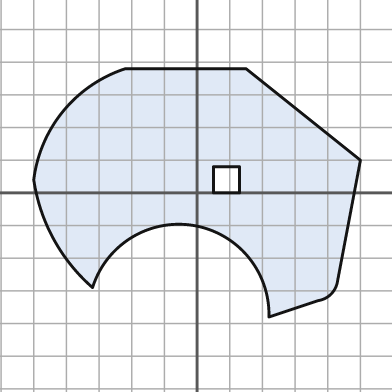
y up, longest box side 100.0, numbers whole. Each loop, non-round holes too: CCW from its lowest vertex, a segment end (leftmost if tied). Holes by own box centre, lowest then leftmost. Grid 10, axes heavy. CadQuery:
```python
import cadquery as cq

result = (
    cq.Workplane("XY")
    .moveTo(22.0, -38.0)
    .lineTo(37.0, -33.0)
    .threePointArc((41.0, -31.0), (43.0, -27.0))
    .lineTo(50.0, 10.0)
    .lineTo(15.0, 38.0)
    .lineTo(-22.0, 38.0)
    .threePointArc((-41.0, 25.0), (-50.0, 4.0))
    .threePointArc((-44.0, -14.0), (-32.0, -29.0))
    .threePointArc((-1.0, -10.0), (22.0, -38.0))
    .close()
    .moveTo(5.0, 0.0)
    .lineTo(13.0, 0.0)
    .lineTo(13.0, 8.0)
    .lineTo(5.0, 8.0)
    .close()
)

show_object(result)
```